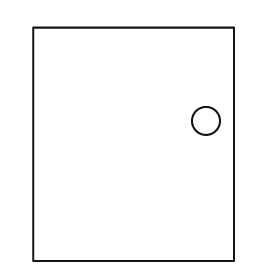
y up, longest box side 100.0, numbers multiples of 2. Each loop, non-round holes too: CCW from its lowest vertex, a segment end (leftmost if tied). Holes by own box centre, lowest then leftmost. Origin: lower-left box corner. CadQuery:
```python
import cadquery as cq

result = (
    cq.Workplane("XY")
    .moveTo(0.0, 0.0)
    .lineTo(86.0, 0.0)
    .lineTo(86.0, 100.0)
    .lineTo(0.0, 100.0)
    .close()
    .moveTo(74.0, 60.0)
    .circle(6.0)
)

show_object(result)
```